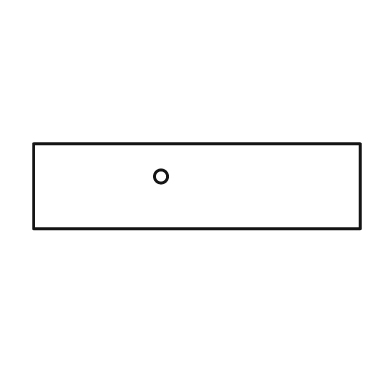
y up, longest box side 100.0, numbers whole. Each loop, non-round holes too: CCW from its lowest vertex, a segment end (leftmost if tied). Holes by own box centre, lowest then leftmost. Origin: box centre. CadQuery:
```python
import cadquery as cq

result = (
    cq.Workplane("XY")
    .moveTo(-50.0, -13.0)
    .lineTo(50.0, -13.0)
    .lineTo(50.0, 13.0)
    .lineTo(-50.0, 13.0)
    .close()
    .moveTo(-11.0, 3.0)
    .circle(2.0)
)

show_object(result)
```